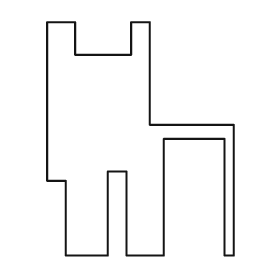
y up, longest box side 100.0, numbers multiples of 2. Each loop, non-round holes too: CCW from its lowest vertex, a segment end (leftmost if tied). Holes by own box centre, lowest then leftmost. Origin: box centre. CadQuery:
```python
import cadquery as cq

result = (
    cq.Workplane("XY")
    .moveTo(-32.0, -50.0)
    .lineTo(-14.0, -50.0)
    .lineTo(-14.0, -14.0)
    .lineTo(-6.0, -14.0)
    .lineTo(-6.0, -50.0)
    .lineTo(10.0, -50.0)
    .lineTo(10.0, 0.0)
    .lineTo(36.0, 0.0)
    .lineTo(36.0, -50.0)
    .lineTo(40.0, -50.0)
    .lineTo(40.0, 6.0)
    .lineTo(4.0, 6.0)
    .lineTo(4.0, 50.0)
    .lineTo(-4.0, 50.0)
    .lineTo(-4.0, 36.0)
    .lineTo(-28.0, 36.0)
    .lineTo(-28.0, 50.0)
    .lineTo(-40.0, 50.0)
    .lineTo(-40.0, -18.0)
    .lineTo(-32.0, -18.0)
    .close()
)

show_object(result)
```